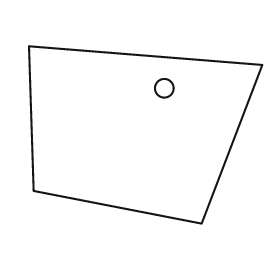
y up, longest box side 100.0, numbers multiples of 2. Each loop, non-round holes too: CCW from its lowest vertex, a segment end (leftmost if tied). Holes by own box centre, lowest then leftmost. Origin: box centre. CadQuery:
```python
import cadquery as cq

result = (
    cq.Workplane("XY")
    .moveTo(24.0, -38.0)
    .lineTo(50.0, 30.0)
    .lineTo(-50.0, 38.0)
    .lineTo(-48.0, -24.0)
    .close()
    .moveTo(8.0, 20.0)
    .circle(4.0)
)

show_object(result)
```